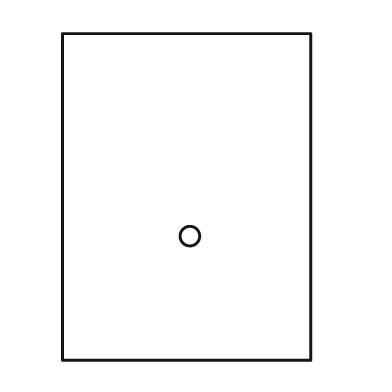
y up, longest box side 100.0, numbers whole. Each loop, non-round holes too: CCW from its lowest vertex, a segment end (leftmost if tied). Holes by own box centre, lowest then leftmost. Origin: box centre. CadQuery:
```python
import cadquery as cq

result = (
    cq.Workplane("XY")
    .moveTo(-38.0, -50.0)
    .lineTo(38.0, -50.0)
    .lineTo(38.0, 50.0)
    .lineTo(-38.0, 50.0)
    .close()
    .moveTo(1.0, -12.0)
    .circle(3.0)
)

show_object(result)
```